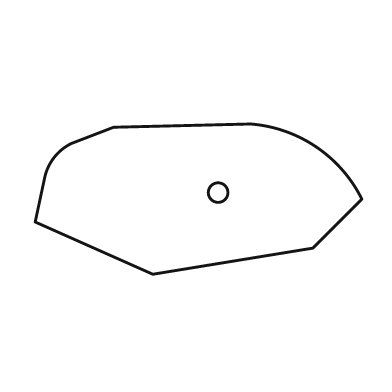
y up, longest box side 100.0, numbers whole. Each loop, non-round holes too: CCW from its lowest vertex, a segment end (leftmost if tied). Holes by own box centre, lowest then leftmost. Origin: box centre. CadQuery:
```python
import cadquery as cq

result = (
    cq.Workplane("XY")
    .moveTo(-14.0, -23.0)
    .lineTo(35.0, -15.0)
    .lineTo(50.0, 0.0)
    .threePointArc((36.0, 16.0), (16.0, 23.0))
    .lineTo(-26.0, 22.0)
    .lineTo(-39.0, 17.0)
    .threePointArc((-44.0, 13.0), (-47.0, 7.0))
    .lineTo(-50.0, -7.0)
    .close()
    .moveTo(6.0, 2.0)
    .circle(3.0)
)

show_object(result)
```